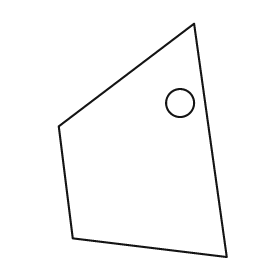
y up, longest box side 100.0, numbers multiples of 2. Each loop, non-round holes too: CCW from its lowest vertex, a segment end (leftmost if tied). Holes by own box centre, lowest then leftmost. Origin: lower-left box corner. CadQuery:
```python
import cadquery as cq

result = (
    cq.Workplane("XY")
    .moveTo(72.0, 0.0)
    .lineTo(58.0, 100.0)
    .lineTo(0.0, 56.0)
    .lineTo(6.0, 8.0)
    .close()
    .moveTo(52.0, 66.0)
    .circle(6.0)
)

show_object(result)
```